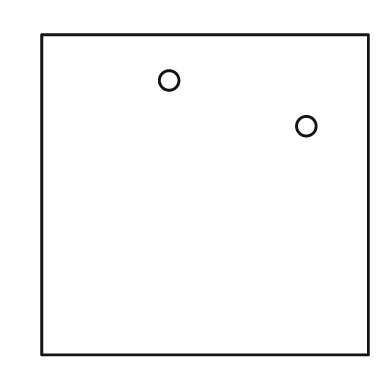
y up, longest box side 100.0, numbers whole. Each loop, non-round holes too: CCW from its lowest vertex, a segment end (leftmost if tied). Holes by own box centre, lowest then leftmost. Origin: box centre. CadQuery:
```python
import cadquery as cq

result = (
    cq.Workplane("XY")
    .moveTo(-50.0, -49.0)
    .lineTo(50.0, -49.0)
    .lineTo(50.0, 49.0)
    .lineTo(-50.0, 49.0)
    .close()
    .moveTo(31.0, 21.0)
    .circle(3.0)
    .moveTo(-11.0, 35.0)
    .circle(3.0)
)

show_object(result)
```